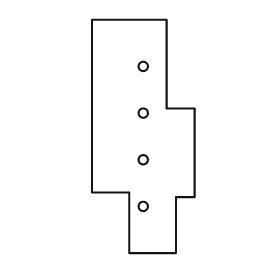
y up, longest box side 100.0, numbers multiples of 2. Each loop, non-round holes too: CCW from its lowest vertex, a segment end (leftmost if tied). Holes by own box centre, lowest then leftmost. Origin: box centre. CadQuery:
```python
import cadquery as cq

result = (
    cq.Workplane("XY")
    .moveTo(-6.0, -50.0)
    .lineTo(14.0, -50.0)
    .lineTo(14.0, -26.0)
    .lineTo(22.0, -26.0)
    .lineTo(22.0, 12.0)
    .lineTo(10.0, 12.0)
    .lineTo(10.0, 50.0)
    .lineTo(-22.0, 50.0)
    .lineTo(-22.0, -24.0)
    .lineTo(-6.0, -24.0)
    .close()
    .moveTo(0.0, -30.0)
    .circle(2.0)
    .moveTo(0.0, -10.0)
    .circle(2.0)
    .moveTo(0.0, 10.0)
    .circle(2.0)
    .moveTo(0.0, 30.0)
    .circle(2.0)
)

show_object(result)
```